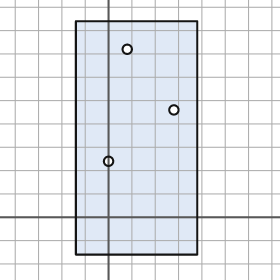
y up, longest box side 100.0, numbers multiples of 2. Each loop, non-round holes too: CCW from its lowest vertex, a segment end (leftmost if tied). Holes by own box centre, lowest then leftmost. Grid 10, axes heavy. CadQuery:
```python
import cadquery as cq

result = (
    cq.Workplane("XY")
    .moveTo(-14.0, -16.0)
    .lineTo(38.0, -16.0)
    .lineTo(38.0, 84.0)
    .lineTo(-14.0, 84.0)
    .close()
    .moveTo(0.0, 24.0)
    .circle(2.0)
    .moveTo(28.0, 46.0)
    .circle(2.0)
    .moveTo(8.0, 72.0)
    .circle(2.0)
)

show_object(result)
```